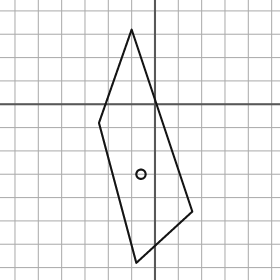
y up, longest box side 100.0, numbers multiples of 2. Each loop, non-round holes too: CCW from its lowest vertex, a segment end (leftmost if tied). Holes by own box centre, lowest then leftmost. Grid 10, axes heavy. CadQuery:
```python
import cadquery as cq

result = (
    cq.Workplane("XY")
    .moveTo(-8.0, -68.0)
    .lineTo(16.0, -46.0)
    .lineTo(-10.0, 32.0)
    .lineTo(-24.0, -8.0)
    .close()
    .moveTo(-6.0, -30.0)
    .circle(2.0)
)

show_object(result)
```